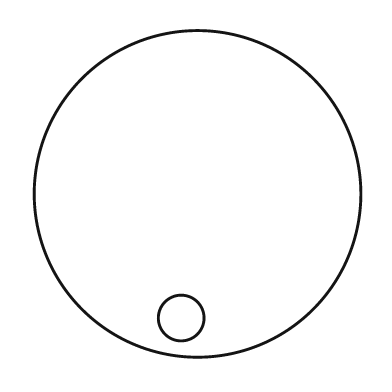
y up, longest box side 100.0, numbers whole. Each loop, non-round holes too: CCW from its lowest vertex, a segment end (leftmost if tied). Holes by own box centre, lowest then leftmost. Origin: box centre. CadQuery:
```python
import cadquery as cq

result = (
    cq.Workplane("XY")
    .moveTo(0.0, 0.0)
    .circle(50.0)
    .moveTo(-5.0, -38.0)
    .circle(7.0)
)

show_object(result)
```